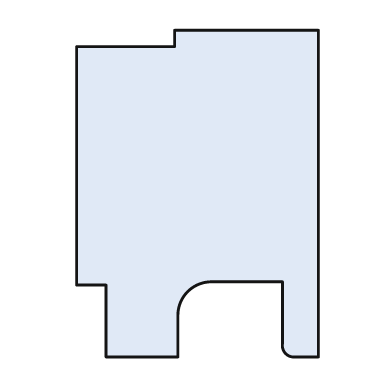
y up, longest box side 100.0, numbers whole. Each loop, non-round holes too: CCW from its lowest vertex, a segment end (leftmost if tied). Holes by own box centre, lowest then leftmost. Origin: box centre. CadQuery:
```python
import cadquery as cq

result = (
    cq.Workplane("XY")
    .moveTo(-28.0, -50.0)
    .lineTo(-6.0, -50.0)
    .lineTo(-6.0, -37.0)
    .threePointArc((-3.0, -30.0), (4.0, -27.0))
    .lineTo(26.0, -27.0)
    .lineTo(26.0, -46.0)
    .threePointArc((27.0, -49.0), (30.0, -50.0))
    .lineTo(37.0, -50.0)
    .lineTo(37.0, 50.0)
    .lineTo(-7.0, 50.0)
    .lineTo(-7.0, 45.0)
    .lineTo(-37.0, 45.0)
    .lineTo(-37.0, -28.0)
    .lineTo(-28.0, -28.0)
    .close()
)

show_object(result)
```